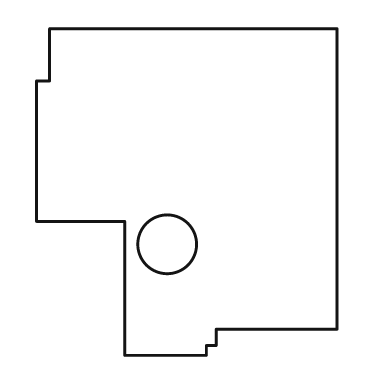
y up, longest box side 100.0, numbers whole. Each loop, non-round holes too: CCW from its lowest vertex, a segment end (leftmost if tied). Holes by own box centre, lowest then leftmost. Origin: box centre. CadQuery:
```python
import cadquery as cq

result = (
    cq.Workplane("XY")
    .moveTo(-19.0, -50.0)
    .lineTo(6.0, -50.0)
    .lineTo(6.0, -47.0)
    .lineTo(9.0, -47.0)
    .lineTo(9.0, -42.0)
    .lineTo(46.0, -42.0)
    .lineTo(46.0, 50.0)
    .lineTo(-42.0, 50.0)
    .lineTo(-42.0, 34.0)
    .lineTo(-46.0, 34.0)
    .lineTo(-46.0, -9.0)
    .lineTo(-19.0, -9.0)
    .close()
    .moveTo(-6.0, -16.0)
    .circle(9.0)
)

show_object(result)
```